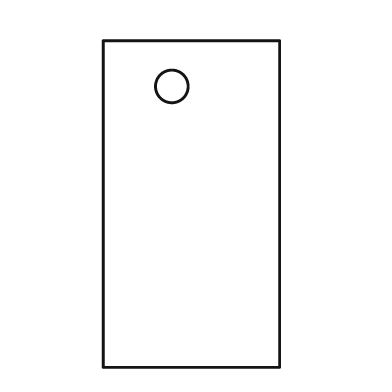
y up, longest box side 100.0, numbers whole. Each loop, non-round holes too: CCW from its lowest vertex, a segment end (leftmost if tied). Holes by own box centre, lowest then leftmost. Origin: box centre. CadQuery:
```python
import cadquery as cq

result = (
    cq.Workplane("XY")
    .moveTo(-27.0, -50.0)
    .lineTo(27.0, -50.0)
    .lineTo(27.0, 50.0)
    .lineTo(-27.0, 50.0)
    .close()
    .moveTo(-6.0, 36.0)
    .circle(5.0)
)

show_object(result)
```